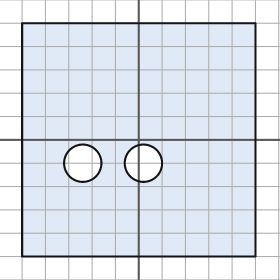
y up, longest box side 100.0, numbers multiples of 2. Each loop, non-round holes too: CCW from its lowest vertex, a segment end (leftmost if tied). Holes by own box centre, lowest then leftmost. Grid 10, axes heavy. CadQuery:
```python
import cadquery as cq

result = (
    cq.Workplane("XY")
    .moveTo(-50.0, -50.0)
    .lineTo(50.0, -50.0)
    .lineTo(50.0, 50.0)
    .lineTo(-50.0, 50.0)
    .close()
    .moveTo(-24.0, -10.0)
    .circle(8.0)
    .moveTo(2.0, -10.0)
    .circle(8.0)
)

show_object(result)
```